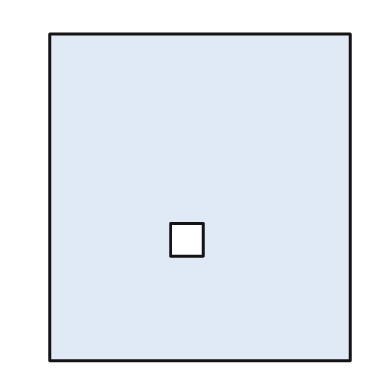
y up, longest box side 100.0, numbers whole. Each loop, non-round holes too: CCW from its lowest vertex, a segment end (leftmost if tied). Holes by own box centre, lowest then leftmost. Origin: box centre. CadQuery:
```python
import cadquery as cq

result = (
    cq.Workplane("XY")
    .moveTo(-46.0, -50.0)
    .lineTo(46.0, -50.0)
    .lineTo(46.0, 50.0)
    .lineTo(-46.0, 50.0)
    .close()
    .moveTo(-9.0, -18.0)
    .lineTo(1.0, -18.0)
    .lineTo(1.0, -8.0)
    .lineTo(-9.0, -8.0)
    .close()
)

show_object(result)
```